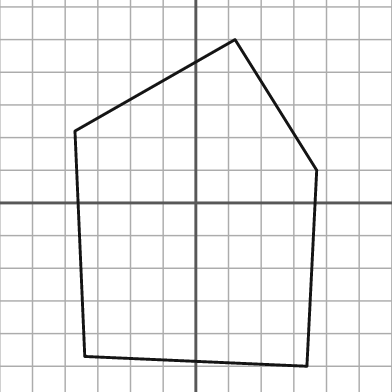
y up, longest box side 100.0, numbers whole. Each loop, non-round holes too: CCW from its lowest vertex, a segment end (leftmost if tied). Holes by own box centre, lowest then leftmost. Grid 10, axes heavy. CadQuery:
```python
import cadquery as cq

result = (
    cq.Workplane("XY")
    .moveTo(34.0, -50.0)
    .lineTo(37.0, 10.0)
    .lineTo(12.0, 50.0)
    .lineTo(-37.0, 22.0)
    .lineTo(-34.0, -47.0)
    .close()
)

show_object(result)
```